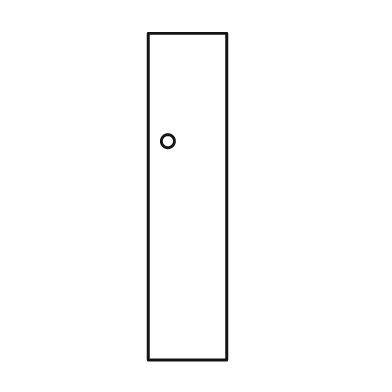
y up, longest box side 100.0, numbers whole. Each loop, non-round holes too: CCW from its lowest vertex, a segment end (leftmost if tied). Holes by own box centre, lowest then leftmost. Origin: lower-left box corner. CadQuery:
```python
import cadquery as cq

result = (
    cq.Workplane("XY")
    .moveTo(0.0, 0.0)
    .lineTo(24.0, 0.0)
    .lineTo(24.0, 100.0)
    .lineTo(0.0, 100.0)
    .close()
    .moveTo(6.0, 67.0)
    .circle(2.0)
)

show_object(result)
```